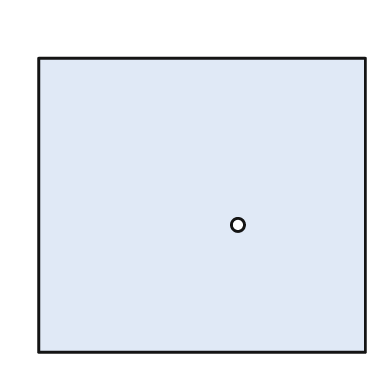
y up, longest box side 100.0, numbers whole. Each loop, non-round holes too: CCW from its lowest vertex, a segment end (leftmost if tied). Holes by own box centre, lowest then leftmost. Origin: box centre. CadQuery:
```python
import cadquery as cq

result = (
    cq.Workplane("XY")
    .moveTo(-50.0, -45.0)
    .lineTo(50.0, -45.0)
    .lineTo(50.0, 45.0)
    .lineTo(-50.0, 45.0)
    .close()
    .moveTo(11.0, -6.0)
    .circle(2.0)
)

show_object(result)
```